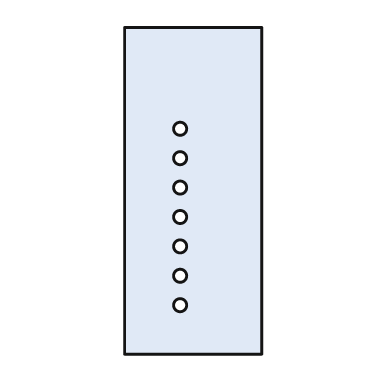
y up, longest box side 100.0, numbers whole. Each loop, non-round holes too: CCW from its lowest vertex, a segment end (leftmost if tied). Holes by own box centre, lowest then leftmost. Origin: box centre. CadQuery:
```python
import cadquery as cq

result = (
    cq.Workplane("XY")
    .moveTo(-21.0, -50.0)
    .lineTo(21.0, -50.0)
    .lineTo(21.0, 50.0)
    .lineTo(-21.0, 50.0)
    .close()
    .moveTo(-4.0, -35.0)
    .circle(2.0)
    .moveTo(-4.0, -26.0)
    .circle(2.0)
    .moveTo(-4.0, -17.0)
    .circle(2.0)
    .moveTo(-4.0, -8.0)
    .circle(2.0)
    .moveTo(-4.0, 1.0)
    .circle(2.0)
    .moveTo(-4.0, 10.0)
    .circle(2.0)
    .moveTo(-4.0, 19.0)
    .circle(2.0)
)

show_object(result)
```